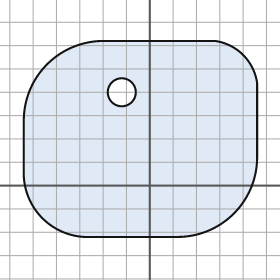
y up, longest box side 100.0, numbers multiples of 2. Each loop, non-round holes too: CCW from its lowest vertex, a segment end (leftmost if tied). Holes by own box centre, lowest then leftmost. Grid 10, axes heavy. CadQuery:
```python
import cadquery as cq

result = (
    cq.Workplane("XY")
    .moveTo(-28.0, -22.0)
    .lineTo(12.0, -22.0)
    .threePointArc((36.0, -12.0), (46.0, 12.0))
    .lineTo(46.0, 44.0)
    .threePointArc((40.0, 56.0), (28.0, 62.0))
    .lineTo(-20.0, 62.0)
    .threePointArc((-44.0, 52.0), (-54.0, 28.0))
    .lineTo(-54.0, 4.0)
    .threePointArc((-46.0, -14.0), (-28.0, -22.0))
    .close()
    .moveTo(-12.0, 40.0)
    .circle(6.0)
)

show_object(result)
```